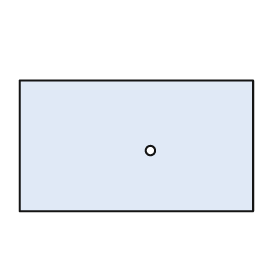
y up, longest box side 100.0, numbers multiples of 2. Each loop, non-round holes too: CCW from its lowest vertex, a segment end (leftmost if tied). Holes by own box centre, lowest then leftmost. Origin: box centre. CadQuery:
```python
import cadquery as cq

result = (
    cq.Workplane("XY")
    .moveTo(-50.0, -28.0)
    .lineTo(50.0, -28.0)
    .lineTo(50.0, 28.0)
    .lineTo(-50.0, 28.0)
    .close()
    .moveTo(6.0, -2.0)
    .circle(2.0)
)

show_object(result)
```